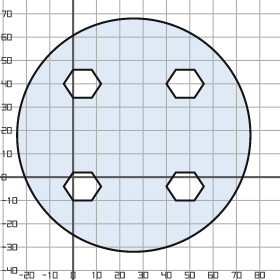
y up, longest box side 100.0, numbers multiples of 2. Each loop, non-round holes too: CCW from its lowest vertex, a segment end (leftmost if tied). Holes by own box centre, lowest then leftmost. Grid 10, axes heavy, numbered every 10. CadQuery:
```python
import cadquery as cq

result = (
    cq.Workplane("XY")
    .moveTo(26.0, 18.0)
    .circle(50.0)
    .moveTo(0.0, -10.0)
    .lineTo(8.0, -10.0)
    .lineTo(12.0, -4.0)
    .lineTo(8.0, 2.0)
    .lineTo(0.0, 2.0)
    .lineTo(-4.0, -4.0)
    .close()
    .moveTo(44.0, -10.0)
    .lineTo(52.0, -10.0)
    .lineTo(56.0, -4.0)
    .lineTo(52.0, 2.0)
    .lineTo(44.0, 2.0)
    .lineTo(40.0, -4.0)
    .close()
    .moveTo(0.0, 34.0)
    .lineTo(8.0, 34.0)
    .lineTo(12.0, 40.0)
    .lineTo(8.0, 46.0)
    .lineTo(0.0, 46.0)
    .lineTo(-4.0, 40.0)
    .close()
    .moveTo(44.0, 34.0)
    .lineTo(52.0, 34.0)
    .lineTo(56.0, 40.0)
    .lineTo(52.0, 46.0)
    .lineTo(44.0, 46.0)
    .lineTo(40.0, 40.0)
    .close()
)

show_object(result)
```